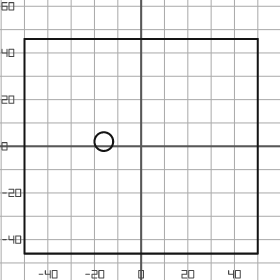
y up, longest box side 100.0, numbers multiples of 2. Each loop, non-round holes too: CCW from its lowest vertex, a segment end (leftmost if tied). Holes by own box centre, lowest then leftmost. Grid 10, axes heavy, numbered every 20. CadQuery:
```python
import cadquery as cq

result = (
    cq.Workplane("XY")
    .moveTo(-50.0, -46.0)
    .lineTo(50.0, -46.0)
    .lineTo(50.0, 46.0)
    .lineTo(-50.0, 46.0)
    .close()
    .moveTo(-16.0, 2.0)
    .circle(4.0)
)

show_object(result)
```